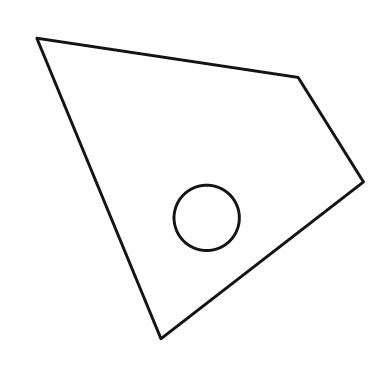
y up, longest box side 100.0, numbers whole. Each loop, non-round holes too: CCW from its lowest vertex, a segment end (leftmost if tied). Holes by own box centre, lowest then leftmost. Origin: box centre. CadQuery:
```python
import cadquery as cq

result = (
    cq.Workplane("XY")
    .moveTo(-12.0, -46.0)
    .lineTo(50.0, 2.0)
    .lineTo(30.0, 34.0)
    .lineTo(-50.0, 46.0)
    .close()
    .moveTo(2.0, -9.0)
    .circle(10.0)
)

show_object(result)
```